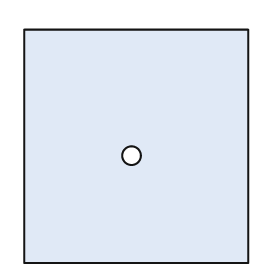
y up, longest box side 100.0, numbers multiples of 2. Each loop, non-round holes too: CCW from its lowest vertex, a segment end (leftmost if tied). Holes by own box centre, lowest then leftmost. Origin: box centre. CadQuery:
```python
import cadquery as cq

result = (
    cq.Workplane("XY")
    .moveTo(-48.0, -50.0)
    .lineTo(48.0, -50.0)
    .lineTo(48.0, 50.0)
    .lineTo(-48.0, 50.0)
    .close()
    .moveTo(-2.0, -4.0)
    .circle(4.0)
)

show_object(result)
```